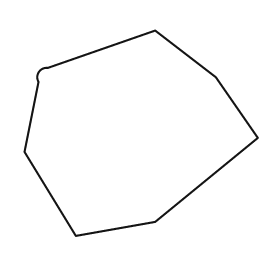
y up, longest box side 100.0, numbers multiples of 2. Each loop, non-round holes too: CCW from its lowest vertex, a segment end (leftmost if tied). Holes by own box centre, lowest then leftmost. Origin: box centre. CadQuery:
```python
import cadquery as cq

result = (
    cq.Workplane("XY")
    .moveTo(-28.0, -44.0)
    .lineTo(6.0, -38.0)
    .lineTo(50.0, -2.0)
    .lineTo(32.0, 24.0)
    .lineTo(6.0, 44.0)
    .lineTo(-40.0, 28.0)
    .threePointArc((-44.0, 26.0), (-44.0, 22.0))
    .lineTo(-50.0, -8.0)
    .close()
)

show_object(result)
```